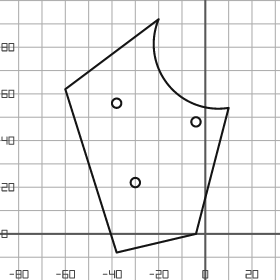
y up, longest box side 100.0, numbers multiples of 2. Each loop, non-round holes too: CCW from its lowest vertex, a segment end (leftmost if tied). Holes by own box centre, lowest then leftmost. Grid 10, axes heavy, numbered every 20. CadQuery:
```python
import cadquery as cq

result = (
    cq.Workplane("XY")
    .moveTo(-38.0, -8.0)
    .lineTo(-4.0, 0.0)
    .lineTo(10.0, 54.0)
    .threePointArc((-16.0, 64.0), (-20.0, 92.0))
    .lineTo(-60.0, 62.0)
    .close()
    .moveTo(-30.0, 22.0)
    .circle(2.0)
    .moveTo(-4.0, 48.0)
    .circle(2.0)
    .moveTo(-38.0, 56.0)
    .circle(2.0)
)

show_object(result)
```